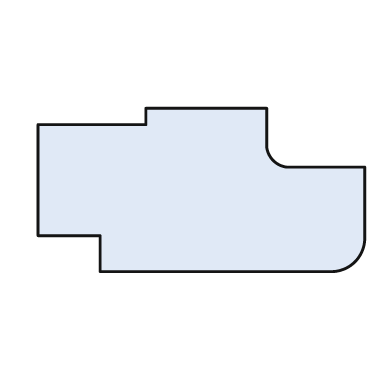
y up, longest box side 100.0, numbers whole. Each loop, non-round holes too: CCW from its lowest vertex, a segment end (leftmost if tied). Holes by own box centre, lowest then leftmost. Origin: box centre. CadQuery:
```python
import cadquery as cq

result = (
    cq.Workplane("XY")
    .moveTo(-31.0, -25.0)
    .lineTo(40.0, -25.0)
    .threePointArc((47.0, -22.0), (50.0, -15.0))
    .lineTo(50.0, 7.0)
    .lineTo(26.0, 7.0)
    .threePointArc((22.0, 9.0), (20.0, 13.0))
    .lineTo(20.0, 25.0)
    .lineTo(-17.0, 25.0)
    .lineTo(-17.0, 20.0)
    .lineTo(-50.0, 20.0)
    .lineTo(-50.0, -14.0)
    .lineTo(-31.0, -14.0)
    .close()
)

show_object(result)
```